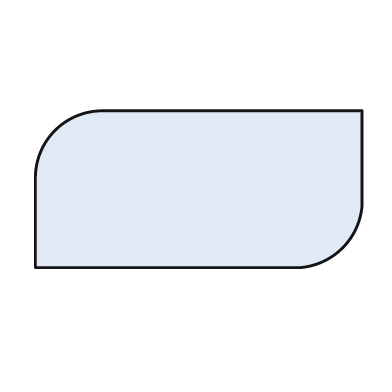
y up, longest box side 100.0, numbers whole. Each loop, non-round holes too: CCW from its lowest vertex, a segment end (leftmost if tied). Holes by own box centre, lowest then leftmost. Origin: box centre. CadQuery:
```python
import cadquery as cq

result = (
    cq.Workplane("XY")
    .moveTo(-50.0, -24.0)
    .lineTo(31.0, -24.0)
    .threePointArc((44.0, -18.0), (50.0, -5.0))
    .lineTo(50.0, 24.0)
    .lineTo(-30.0, 24.0)
    .threePointArc((-44.0, 18.0), (-50.0, 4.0))
    .close()
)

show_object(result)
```